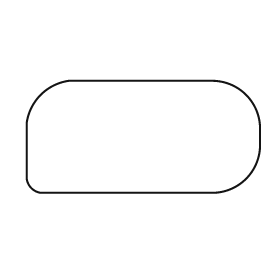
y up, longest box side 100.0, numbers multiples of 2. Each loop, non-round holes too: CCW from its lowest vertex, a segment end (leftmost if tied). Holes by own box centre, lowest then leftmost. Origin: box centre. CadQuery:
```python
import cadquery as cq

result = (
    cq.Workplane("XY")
    .moveTo(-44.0, -24.0)
    .lineTo(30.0, -24.0)
    .threePointArc((44.0, -18.0), (50.0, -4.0))
    .lineTo(50.0, 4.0)
    .threePointArc((44.0, 18.0), (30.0, 24.0))
    .lineTo(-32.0, 24.0)
    .threePointArc((-44.0, 18.0), (-50.0, 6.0))
    .lineTo(-50.0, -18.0)
    .threePointArc((-48.0, -22.0), (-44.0, -24.0))
    .close()
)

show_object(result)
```